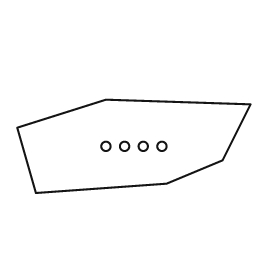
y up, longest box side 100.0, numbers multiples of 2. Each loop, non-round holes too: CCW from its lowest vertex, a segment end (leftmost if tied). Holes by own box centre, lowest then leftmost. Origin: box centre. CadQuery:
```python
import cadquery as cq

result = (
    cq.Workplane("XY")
    .moveTo(-42.0, -20.0)
    .lineTo(14.0, -16.0)
    .lineTo(38.0, -6.0)
    .lineTo(50.0, 18.0)
    .lineTo(-12.0, 20.0)
    .lineTo(-50.0, 8.0)
    .close()
    .moveTo(-12.0, 0.0)
    .circle(2.0)
    .moveTo(-4.0, 0.0)
    .circle(2.0)
    .moveTo(4.0, 0.0)
    .circle(2.0)
    .moveTo(12.0, 0.0)
    .circle(2.0)
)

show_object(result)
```